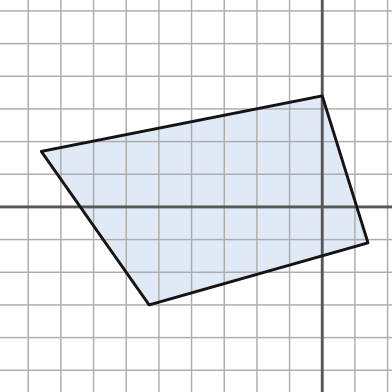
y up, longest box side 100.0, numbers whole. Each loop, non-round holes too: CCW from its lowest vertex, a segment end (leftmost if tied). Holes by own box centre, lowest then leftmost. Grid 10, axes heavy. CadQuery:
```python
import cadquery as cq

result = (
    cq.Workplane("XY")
    .moveTo(-53.0, -30.0)
    .lineTo(14.0, -11.0)
    .lineTo(0.0, 34.0)
    .lineTo(-86.0, 17.0)
    .close()
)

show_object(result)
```